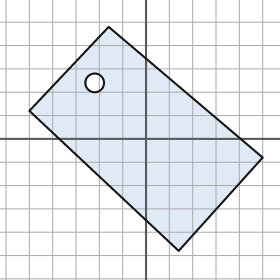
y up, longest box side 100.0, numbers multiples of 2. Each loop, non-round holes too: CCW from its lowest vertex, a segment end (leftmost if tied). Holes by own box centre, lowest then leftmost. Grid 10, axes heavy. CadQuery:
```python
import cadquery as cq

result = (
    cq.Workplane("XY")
    .moveTo(14.0, -48.0)
    .lineTo(50.0, -8.0)
    .lineTo(-16.0, 48.0)
    .lineTo(-50.0, 12.0)
    .close()
    .moveTo(-22.0, 24.0)
    .circle(4.0)
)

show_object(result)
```